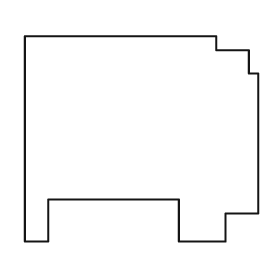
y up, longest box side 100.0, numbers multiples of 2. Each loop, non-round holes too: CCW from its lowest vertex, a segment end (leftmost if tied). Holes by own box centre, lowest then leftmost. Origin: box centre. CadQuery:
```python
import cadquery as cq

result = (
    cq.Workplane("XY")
    .moveTo(-50.0, -44.0)
    .lineTo(-40.0, -44.0)
    .lineTo(-40.0, -26.0)
    .lineTo(16.0, -26.0)
    .lineTo(16.0, -44.0)
    .lineTo(36.0, -44.0)
    .lineTo(36.0, -32.0)
    .lineTo(50.0, -32.0)
    .lineTo(50.0, 28.0)
    .lineTo(46.0, 28.0)
    .lineTo(46.0, 38.0)
    .lineTo(32.0, 38.0)
    .lineTo(32.0, 44.0)
    .lineTo(-50.0, 44.0)
    .close()
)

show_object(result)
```